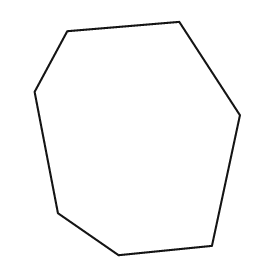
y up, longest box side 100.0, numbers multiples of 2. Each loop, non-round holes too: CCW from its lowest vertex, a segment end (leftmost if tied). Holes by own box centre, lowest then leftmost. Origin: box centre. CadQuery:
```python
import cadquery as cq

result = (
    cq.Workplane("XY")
    .moveTo(-8.0, -50.0)
    .lineTo(32.0, -46.0)
    .lineTo(44.0, 10.0)
    .lineTo(18.0, 50.0)
    .lineTo(-30.0, 46.0)
    .lineTo(-44.0, 20.0)
    .lineTo(-34.0, -32.0)
    .close()
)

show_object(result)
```